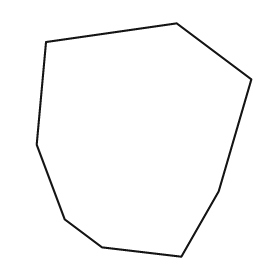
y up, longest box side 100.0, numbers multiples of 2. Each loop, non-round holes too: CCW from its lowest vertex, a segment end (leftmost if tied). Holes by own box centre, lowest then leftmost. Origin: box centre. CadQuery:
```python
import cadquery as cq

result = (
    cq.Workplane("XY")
    .moveTo(16.0, -50.0)
    .lineTo(32.0, -22.0)
    .lineTo(46.0, 26.0)
    .lineTo(14.0, 50.0)
    .lineTo(-42.0, 42.0)
    .lineTo(-46.0, -2.0)
    .lineTo(-34.0, -34.0)
    .lineTo(-18.0, -46.0)
    .close()
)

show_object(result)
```